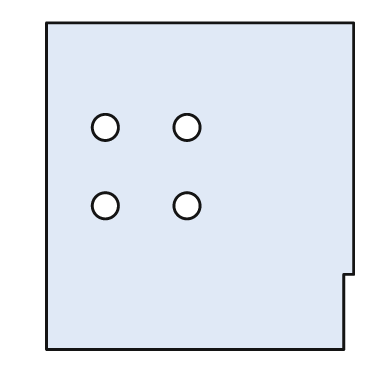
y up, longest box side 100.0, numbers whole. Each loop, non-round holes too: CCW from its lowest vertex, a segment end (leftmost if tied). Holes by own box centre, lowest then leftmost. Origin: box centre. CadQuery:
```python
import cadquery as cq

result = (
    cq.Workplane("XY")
    .moveTo(-47.0, -50.0)
    .lineTo(44.0, -50.0)
    .lineTo(44.0, -27.0)
    .lineTo(47.0, -27.0)
    .lineTo(47.0, 50.0)
    .lineTo(-47.0, 50.0)
    .close()
    .moveTo(-29.0, -6.0)
    .circle(4.0)
    .moveTo(-4.0, -6.0)
    .circle(4.0)
    .moveTo(-29.0, 18.0)
    .circle(4.0)
    .moveTo(-4.0, 18.0)
    .circle(4.0)
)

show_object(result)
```